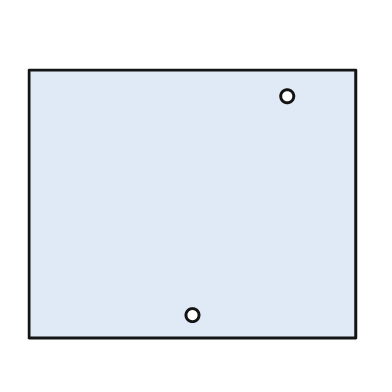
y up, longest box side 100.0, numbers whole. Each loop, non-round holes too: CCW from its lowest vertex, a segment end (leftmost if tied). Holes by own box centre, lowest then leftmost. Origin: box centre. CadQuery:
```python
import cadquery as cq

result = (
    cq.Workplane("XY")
    .moveTo(-50.0, -41.0)
    .lineTo(50.0, -41.0)
    .lineTo(50.0, 41.0)
    .lineTo(-50.0, 41.0)
    .close()
    .moveTo(0.0, -34.0)
    .circle(2.0)
    .moveTo(29.0, 33.0)
    .circle(2.0)
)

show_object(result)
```